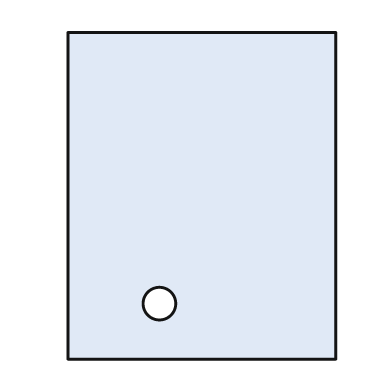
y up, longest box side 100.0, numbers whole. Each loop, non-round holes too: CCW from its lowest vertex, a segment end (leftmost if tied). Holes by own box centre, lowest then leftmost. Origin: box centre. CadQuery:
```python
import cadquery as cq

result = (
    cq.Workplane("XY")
    .moveTo(-41.0, -50.0)
    .lineTo(41.0, -50.0)
    .lineTo(41.0, 50.0)
    .lineTo(-41.0, 50.0)
    .close()
    .moveTo(-13.0, -33.0)
    .circle(5.0)
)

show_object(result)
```